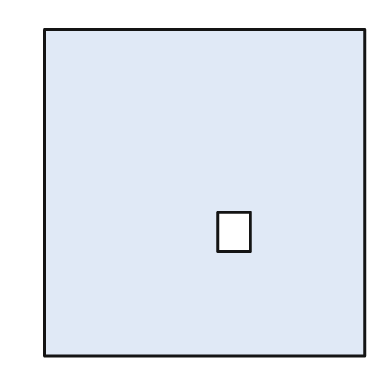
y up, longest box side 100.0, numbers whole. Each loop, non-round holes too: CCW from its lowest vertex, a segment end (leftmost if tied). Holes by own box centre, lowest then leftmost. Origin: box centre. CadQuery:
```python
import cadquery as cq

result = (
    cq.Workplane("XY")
    .moveTo(-49.0, -50.0)
    .lineTo(49.0, -50.0)
    .lineTo(49.0, 50.0)
    .lineTo(-49.0, 50.0)
    .close()
    .moveTo(4.0, -18.0)
    .lineTo(14.0, -18.0)
    .lineTo(14.0, -6.0)
    .lineTo(4.0, -6.0)
    .close()
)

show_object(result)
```